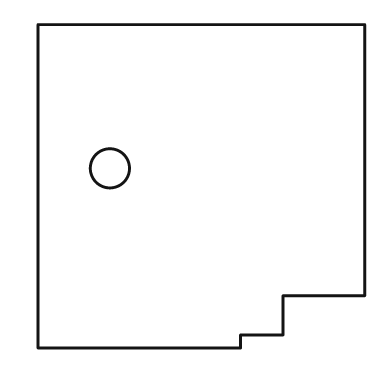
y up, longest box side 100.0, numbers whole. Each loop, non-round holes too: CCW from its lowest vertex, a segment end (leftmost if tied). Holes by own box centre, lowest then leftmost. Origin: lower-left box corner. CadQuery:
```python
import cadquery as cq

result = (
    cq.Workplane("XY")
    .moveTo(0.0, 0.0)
    .lineTo(62.0, 0.0)
    .lineTo(62.0, 4.0)
    .lineTo(75.0, 4.0)
    .lineTo(75.0, 16.0)
    .lineTo(100.0, 16.0)
    .lineTo(100.0, 99.0)
    .lineTo(0.0, 99.0)
    .close()
    .moveTo(22.0, 55.0)
    .circle(6.0)
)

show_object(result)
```